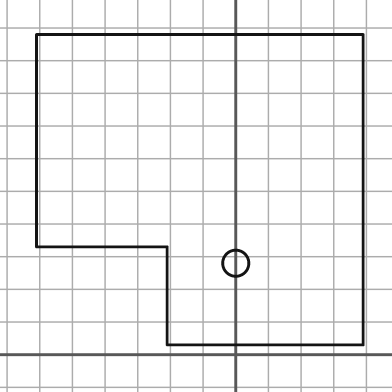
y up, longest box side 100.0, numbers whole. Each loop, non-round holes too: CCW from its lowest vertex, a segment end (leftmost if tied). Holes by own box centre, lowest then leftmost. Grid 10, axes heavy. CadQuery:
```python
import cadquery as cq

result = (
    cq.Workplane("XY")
    .moveTo(-21.0, 3.0)
    .lineTo(39.0, 3.0)
    .lineTo(39.0, 98.0)
    .lineTo(-61.0, 98.0)
    .lineTo(-61.0, 33.0)
    .lineTo(-21.0, 33.0)
    .close()
    .moveTo(0.0, 28.0)
    .circle(4.0)
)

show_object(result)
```